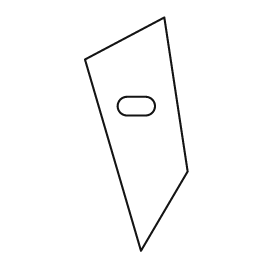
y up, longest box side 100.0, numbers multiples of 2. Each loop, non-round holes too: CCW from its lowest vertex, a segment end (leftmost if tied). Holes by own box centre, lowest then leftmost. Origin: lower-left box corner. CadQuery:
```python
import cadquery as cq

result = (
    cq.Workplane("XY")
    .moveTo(24.0, 0.0)
    .lineTo(44.0, 34.0)
    .lineTo(34.0, 100.0)
    .lineTo(0.0, 82.0)
    .close()
    .moveTo(18.0, 58.0)
    .lineTo(26.0, 58.0)
    .threePointArc((30.0, 62.0), (26.0, 66.0))
    .lineTo(18.0, 66.0)
    .threePointArc((14.0, 62.0), (18.0, 58.0))
    .close()
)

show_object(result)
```